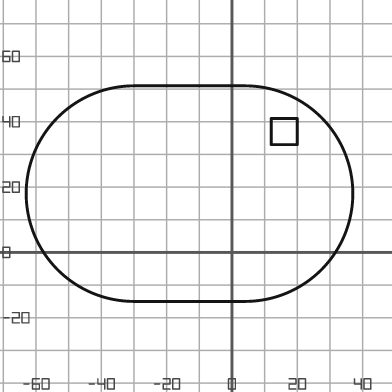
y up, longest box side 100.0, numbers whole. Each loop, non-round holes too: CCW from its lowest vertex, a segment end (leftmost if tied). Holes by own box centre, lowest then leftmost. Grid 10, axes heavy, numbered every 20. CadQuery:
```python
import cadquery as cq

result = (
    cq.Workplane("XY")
    .moveTo(-30.0, -15.0)
    .lineTo(4.0, -15.0)
    .threePointArc((37.0, 18.0), (4.0, 51.0))
    .lineTo(-30.0, 51.0)
    .threePointArc((-63.0, 18.0), (-30.0, -15.0))
    .close()
    .moveTo(12.0, 33.0)
    .lineTo(20.0, 33.0)
    .lineTo(20.0, 41.0)
    .lineTo(12.0, 41.0)
    .close()
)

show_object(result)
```